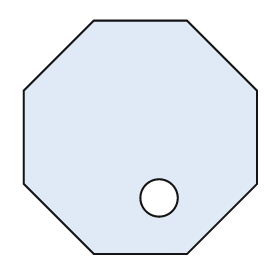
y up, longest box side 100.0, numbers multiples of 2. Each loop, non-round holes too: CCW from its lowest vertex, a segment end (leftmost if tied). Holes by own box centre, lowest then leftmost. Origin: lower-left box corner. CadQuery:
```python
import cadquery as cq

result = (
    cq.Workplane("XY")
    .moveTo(30.0, 0.0)
    .lineTo(70.0, 0.0)
    .lineTo(100.0, 30.0)
    .lineTo(100.0, 70.0)
    .lineTo(70.0, 100.0)
    .lineTo(30.0, 100.0)
    .lineTo(0.0, 70.0)
    .lineTo(0.0, 30.0)
    .close()
    .moveTo(58.0, 24.0)
    .circle(8.0)
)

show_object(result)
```